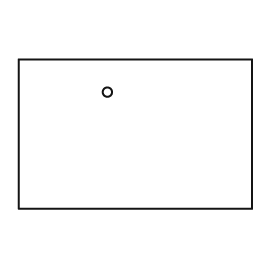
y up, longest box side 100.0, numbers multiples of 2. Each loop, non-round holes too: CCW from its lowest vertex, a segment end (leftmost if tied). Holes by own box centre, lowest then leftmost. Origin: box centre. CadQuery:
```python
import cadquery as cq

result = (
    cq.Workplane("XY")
    .moveTo(-50.0, -32.0)
    .lineTo(50.0, -32.0)
    .lineTo(50.0, 32.0)
    .lineTo(-50.0, 32.0)
    .close()
    .moveTo(-12.0, 18.0)
    .circle(2.0)
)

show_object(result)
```